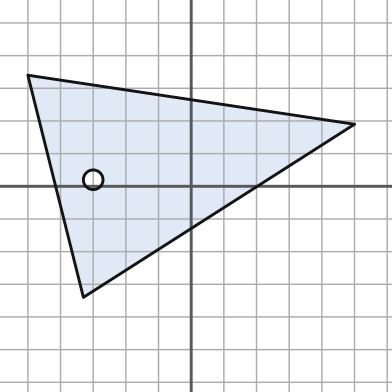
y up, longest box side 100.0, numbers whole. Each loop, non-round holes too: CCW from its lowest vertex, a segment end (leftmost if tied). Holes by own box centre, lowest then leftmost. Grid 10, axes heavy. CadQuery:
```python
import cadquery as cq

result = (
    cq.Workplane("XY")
    .moveTo(-33.0, -34.0)
    .lineTo(50.0, 19.0)
    .lineTo(-50.0, 34.0)
    .close()
    .moveTo(-30.0, 2.0)
    .circle(3.0)
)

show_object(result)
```